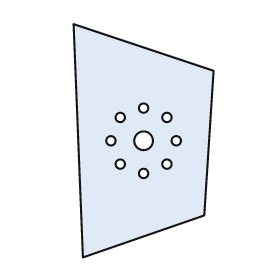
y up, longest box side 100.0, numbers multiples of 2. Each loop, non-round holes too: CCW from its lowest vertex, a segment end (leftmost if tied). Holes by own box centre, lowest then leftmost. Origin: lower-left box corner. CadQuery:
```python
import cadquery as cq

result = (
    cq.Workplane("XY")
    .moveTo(4.0, 0.0)
    .lineTo(56.0, 18.0)
    .lineTo(60.0, 80.0)
    .lineTo(0.0, 100.0)
    .close()
    .moveTo(30.0, 36.0)
    .circle(2.0)
    .moveTo(20.0, 40.0)
    .circle(2.0)
    .moveTo(40.0, 40.0)
    .circle(2.0)
    .moveTo(16.0, 50.0)
    .circle(2.0)
    .moveTo(30.0, 50.0)
    .circle(4.0)
    .moveTo(44.0, 50.0)
    .circle(2.0)
    .moveTo(20.0, 60.0)
    .circle(2.0)
    .moveTo(40.0, 60.0)
    .circle(2.0)
    .moveTo(30.0, 64.0)
    .circle(2.0)
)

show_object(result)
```